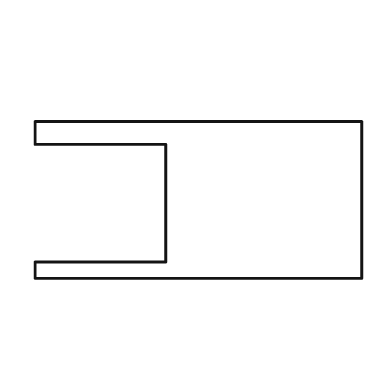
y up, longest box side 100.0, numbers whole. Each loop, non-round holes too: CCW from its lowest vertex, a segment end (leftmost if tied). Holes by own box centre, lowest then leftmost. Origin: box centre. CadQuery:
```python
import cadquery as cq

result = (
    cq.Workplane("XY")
    .moveTo(-50.0, -24.0)
    .lineTo(50.0, -24.0)
    .lineTo(50.0, 24.0)
    .lineTo(-50.0, 24.0)
    .lineTo(-50.0, 17.0)
    .lineTo(-10.0, 17.0)
    .lineTo(-10.0, -19.0)
    .lineTo(-50.0, -19.0)
    .close()
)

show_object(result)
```